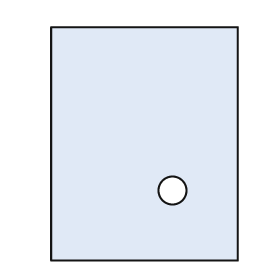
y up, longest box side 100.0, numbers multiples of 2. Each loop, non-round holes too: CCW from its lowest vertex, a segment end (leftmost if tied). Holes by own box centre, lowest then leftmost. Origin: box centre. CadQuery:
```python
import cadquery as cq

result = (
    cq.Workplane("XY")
    .moveTo(-40.0, -50.0)
    .lineTo(40.0, -50.0)
    .lineTo(40.0, 50.0)
    .lineTo(-40.0, 50.0)
    .close()
    .moveTo(12.0, -20.0)
    .circle(6.0)
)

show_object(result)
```